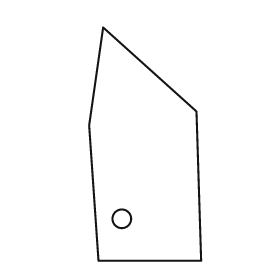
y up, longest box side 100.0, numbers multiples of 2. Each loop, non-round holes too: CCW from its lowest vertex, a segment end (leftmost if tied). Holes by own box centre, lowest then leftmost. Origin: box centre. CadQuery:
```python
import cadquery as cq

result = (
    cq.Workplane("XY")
    .moveTo(-20.0, -50.0)
    .lineTo(24.0, -50.0)
    .lineTo(22.0, 14.0)
    .lineTo(-18.0, 50.0)
    .lineTo(-24.0, 8.0)
    .close()
    .moveTo(-10.0, -32.0)
    .circle(4.0)
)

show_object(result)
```